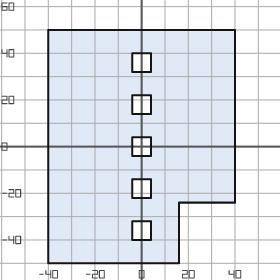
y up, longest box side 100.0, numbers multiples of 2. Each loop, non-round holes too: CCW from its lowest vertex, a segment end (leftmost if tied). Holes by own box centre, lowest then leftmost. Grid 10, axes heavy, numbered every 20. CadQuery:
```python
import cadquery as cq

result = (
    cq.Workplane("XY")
    .moveTo(-40.0, -50.0)
    .lineTo(16.0, -50.0)
    .lineTo(16.0, -24.0)
    .lineTo(40.0, -24.0)
    .lineTo(40.0, 50.0)
    .lineTo(-40.0, 50.0)
    .close()
    .moveTo(-4.0, -40.0)
    .lineTo(4.0, -40.0)
    .lineTo(4.0, -32.0)
    .lineTo(-4.0, -32.0)
    .close()
    .moveTo(-4.0, -22.0)
    .lineTo(4.0, -22.0)
    .lineTo(4.0, -14.0)
    .lineTo(-4.0, -14.0)
    .close()
    .moveTo(-4.0, -4.0)
    .lineTo(4.0, -4.0)
    .lineTo(4.0, 4.0)
    .lineTo(-4.0, 4.0)
    .close()
    .moveTo(-4.0, 14.0)
    .lineTo(4.0, 14.0)
    .lineTo(4.0, 22.0)
    .lineTo(-4.0, 22.0)
    .close()
    .moveTo(-4.0, 32.0)
    .lineTo(4.0, 32.0)
    .lineTo(4.0, 40.0)
    .lineTo(-4.0, 40.0)
    .close()
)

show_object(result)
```